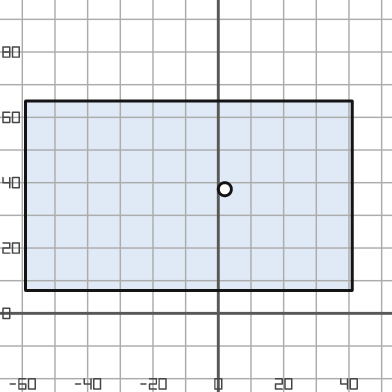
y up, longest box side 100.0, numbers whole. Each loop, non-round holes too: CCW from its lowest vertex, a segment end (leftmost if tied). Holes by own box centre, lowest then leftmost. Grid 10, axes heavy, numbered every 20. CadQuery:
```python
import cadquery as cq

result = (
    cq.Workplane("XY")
    .moveTo(-59.0, 7.0)
    .lineTo(41.0, 7.0)
    .lineTo(41.0, 65.0)
    .lineTo(-59.0, 65.0)
    .close()
    .moveTo(2.0, 38.0)
    .circle(2.0)
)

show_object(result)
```